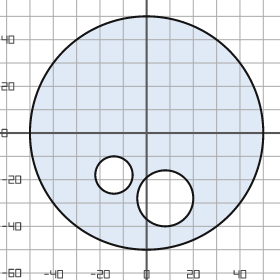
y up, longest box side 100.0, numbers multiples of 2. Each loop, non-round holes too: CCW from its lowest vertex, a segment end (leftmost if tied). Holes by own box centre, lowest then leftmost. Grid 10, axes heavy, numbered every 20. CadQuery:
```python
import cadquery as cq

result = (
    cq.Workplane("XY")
    .moveTo(0.0, 0.0)
    .circle(50.0)
    .moveTo(8.0, -28.0)
    .circle(12.0)
    .moveTo(-14.0, -18.0)
    .circle(8.0)
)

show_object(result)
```